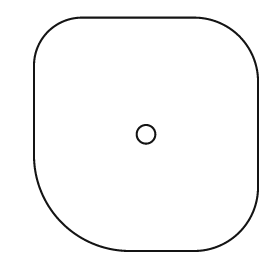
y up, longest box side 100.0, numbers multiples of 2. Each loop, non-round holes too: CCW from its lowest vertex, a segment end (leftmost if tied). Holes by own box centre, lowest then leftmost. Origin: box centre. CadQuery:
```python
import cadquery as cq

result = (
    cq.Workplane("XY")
    .moveTo(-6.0, -50.0)
    .lineTo(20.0, -50.0)
    .threePointArc((40.0, -42.0), (48.0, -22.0))
    .lineTo(48.0, 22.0)
    .threePointArc((40.0, 42.0), (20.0, 50.0))
    .lineTo(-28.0, 50.0)
    .threePointArc((-42.0, 44.0), (-48.0, 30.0))
    .lineTo(-48.0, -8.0)
    .threePointArc((-36.0, -38.0), (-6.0, -50.0))
    .close()
    .moveTo(0.0, 0.0)
    .circle(4.0)
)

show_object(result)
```